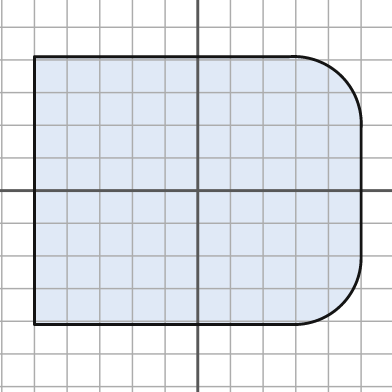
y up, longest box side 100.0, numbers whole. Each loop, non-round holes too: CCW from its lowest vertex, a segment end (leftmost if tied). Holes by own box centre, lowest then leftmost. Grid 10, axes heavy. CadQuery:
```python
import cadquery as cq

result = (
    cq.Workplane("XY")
    .moveTo(-50.0, -41.0)
    .lineTo(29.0, -41.0)
    .threePointArc((44.0, -35.0), (50.0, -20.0))
    .lineTo(50.0, 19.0)
    .threePointArc((44.0, 35.0), (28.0, 41.0))
    .lineTo(-50.0, 41.0)
    .close()
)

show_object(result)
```